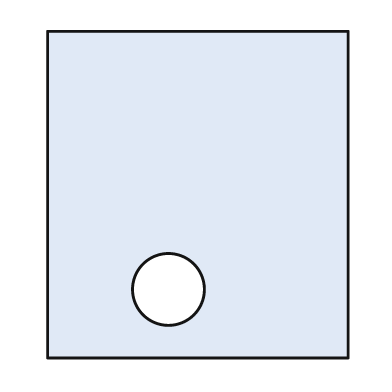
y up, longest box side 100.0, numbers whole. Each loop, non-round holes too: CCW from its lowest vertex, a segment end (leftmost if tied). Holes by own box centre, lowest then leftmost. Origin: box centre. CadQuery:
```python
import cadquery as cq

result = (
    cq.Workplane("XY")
    .moveTo(-46.0, -50.0)
    .lineTo(46.0, -50.0)
    .lineTo(46.0, 50.0)
    .lineTo(-46.0, 50.0)
    .close()
    .moveTo(-9.0, -29.0)
    .circle(11.0)
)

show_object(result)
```